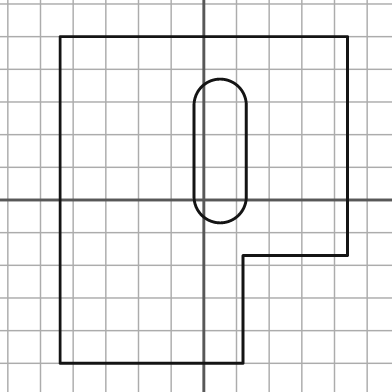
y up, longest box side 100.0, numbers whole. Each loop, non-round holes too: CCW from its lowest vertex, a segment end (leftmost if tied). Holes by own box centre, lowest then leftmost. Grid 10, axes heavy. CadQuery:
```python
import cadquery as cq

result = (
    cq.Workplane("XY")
    .moveTo(-44.0, -50.0)
    .lineTo(12.0, -50.0)
    .lineTo(12.0, -17.0)
    .lineTo(44.0, -17.0)
    .lineTo(44.0, 50.0)
    .lineTo(-44.0, 50.0)
    .close()
    .moveTo(-3.0, 1.0)
    .threePointArc((5.0, -7.0), (13.0, 1.0))
    .lineTo(13.0, 29.0)
    .threePointArc((5.0, 37.0), (-3.0, 29.0))
    .close()
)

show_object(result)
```